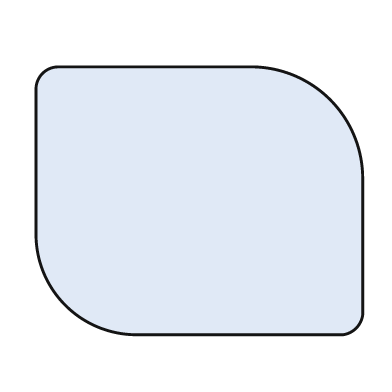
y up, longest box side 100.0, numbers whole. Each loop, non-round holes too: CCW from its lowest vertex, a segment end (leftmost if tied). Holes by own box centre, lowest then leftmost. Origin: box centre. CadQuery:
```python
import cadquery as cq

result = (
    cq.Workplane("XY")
    .moveTo(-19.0, -41.0)
    .lineTo(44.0, -41.0)
    .threePointArc((48.0, -39.0), (50.0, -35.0))
    .lineTo(50.0, 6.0)
    .threePointArc((40.0, 31.0), (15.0, 41.0))
    .lineTo(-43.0, 41.0)
    .threePointArc((-48.0, 39.0), (-50.0, 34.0))
    .lineTo(-50.0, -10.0)
    .threePointArc((-41.0, -32.0), (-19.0, -41.0))
    .close()
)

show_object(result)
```